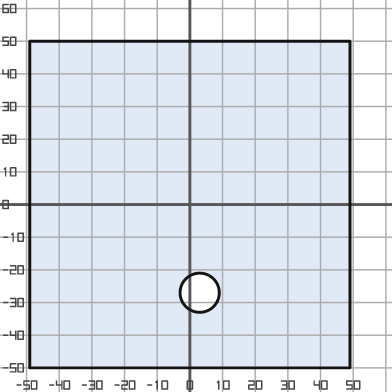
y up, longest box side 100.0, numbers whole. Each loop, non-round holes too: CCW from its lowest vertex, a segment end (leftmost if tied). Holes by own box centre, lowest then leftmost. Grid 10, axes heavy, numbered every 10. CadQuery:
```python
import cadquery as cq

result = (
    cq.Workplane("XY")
    .moveTo(-49.0, -50.0)
    .lineTo(49.0, -50.0)
    .lineTo(49.0, 50.0)
    .lineTo(-49.0, 50.0)
    .close()
    .moveTo(3.0, -27.0)
    .circle(6.0)
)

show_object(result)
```